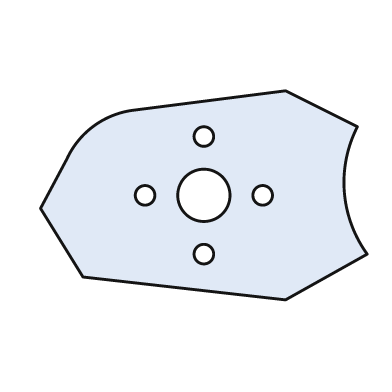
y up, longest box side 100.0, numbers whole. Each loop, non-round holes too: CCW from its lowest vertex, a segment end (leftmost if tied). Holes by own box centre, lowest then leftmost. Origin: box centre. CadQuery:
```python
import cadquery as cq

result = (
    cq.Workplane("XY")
    .moveTo(25.0, -32.0)
    .lineTo(50.0, -18.0)
    .threePointArc((43.0, 1.0), (47.0, 21.0))
    .lineTo(25.0, 32.0)
    .lineTo(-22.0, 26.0)
    .threePointArc((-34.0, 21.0), (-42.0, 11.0))
    .lineTo(-50.0, -4.0)
    .lineTo(-37.0, -25.0)
    .close()
    .moveTo(0.0, -18.0)
    .circle(3.0)
    .moveTo(-18.0, 0.0)
    .circle(3.0)
    .moveTo(0.0, 0.0)
    .circle(8.0)
    .moveTo(18.0, 0.0)
    .circle(3.0)
    .moveTo(0.0, 18.0)
    .circle(3.0)
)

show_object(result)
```